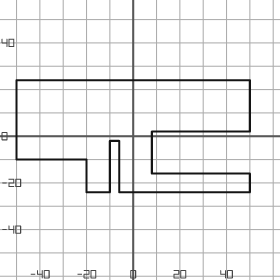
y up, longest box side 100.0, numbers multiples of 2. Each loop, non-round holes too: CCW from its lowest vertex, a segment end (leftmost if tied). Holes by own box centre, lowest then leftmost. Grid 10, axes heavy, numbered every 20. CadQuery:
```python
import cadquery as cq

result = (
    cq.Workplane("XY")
    .moveTo(-20.0, -24.0)
    .lineTo(-10.0, -24.0)
    .lineTo(-10.0, -2.0)
    .lineTo(-6.0, -2.0)
    .lineTo(-6.0, -24.0)
    .lineTo(50.0, -24.0)
    .lineTo(50.0, -16.0)
    .lineTo(8.0, -16.0)
    .lineTo(8.0, 2.0)
    .lineTo(50.0, 2.0)
    .lineTo(50.0, 24.0)
    .lineTo(-50.0, 24.0)
    .lineTo(-50.0, -10.0)
    .lineTo(-20.0, -10.0)
    .close()
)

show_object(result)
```